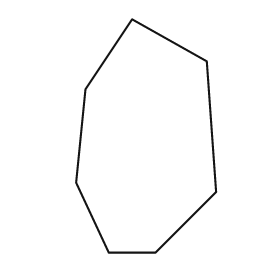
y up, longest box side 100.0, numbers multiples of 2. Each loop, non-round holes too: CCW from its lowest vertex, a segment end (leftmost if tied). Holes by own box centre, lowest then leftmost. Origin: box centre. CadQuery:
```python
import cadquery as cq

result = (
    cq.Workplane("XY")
    .moveTo(-16.0, -50.0)
    .lineTo(4.0, -50.0)
    .lineTo(30.0, -24.0)
    .lineTo(26.0, 32.0)
    .lineTo(-6.0, 50.0)
    .lineTo(-26.0, 20.0)
    .lineTo(-30.0, -20.0)
    .close()
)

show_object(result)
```